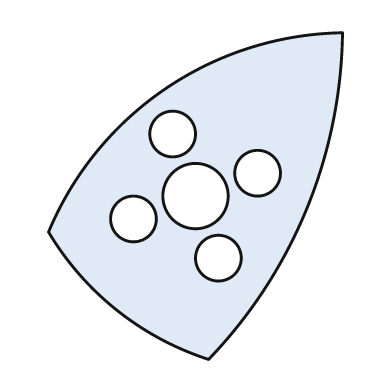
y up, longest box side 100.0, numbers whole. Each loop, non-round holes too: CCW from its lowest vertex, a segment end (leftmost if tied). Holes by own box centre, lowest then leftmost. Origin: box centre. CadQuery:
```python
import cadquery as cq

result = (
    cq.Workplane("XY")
    .moveTo(4.0, -50.0)
    .threePointArc((34.0, -4.0), (45.0, 50.0))
    .threePointArc((-9.0, 33.0), (-45.0, -11.0))
    .threePointArc((-24.0, -35.0), (4.0, -50.0))
    .close()
    .moveTo(7.0, -19.0)
    .circle(7.0)
    .moveTo(-19.0, -7.0)
    .circle(7.0)
    .moveTo(0.0, 0.0)
    .circle(10.0)
    .moveTo(19.0, 7.0)
    .circle(7.0)
    .moveTo(-7.0, 19.0)
    .circle(7.0)
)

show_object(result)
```